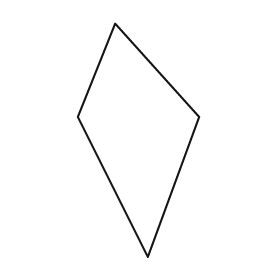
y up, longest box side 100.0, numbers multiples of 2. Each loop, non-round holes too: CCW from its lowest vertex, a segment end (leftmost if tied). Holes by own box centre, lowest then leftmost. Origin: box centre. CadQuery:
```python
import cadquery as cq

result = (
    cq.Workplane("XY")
    .moveTo(4.0, -50.0)
    .lineTo(26.0, 10.0)
    .lineTo(-10.0, 50.0)
    .lineTo(-26.0, 10.0)
    .close()
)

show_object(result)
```